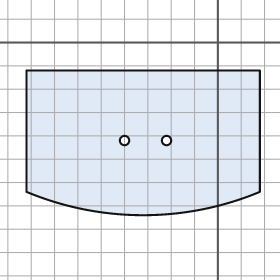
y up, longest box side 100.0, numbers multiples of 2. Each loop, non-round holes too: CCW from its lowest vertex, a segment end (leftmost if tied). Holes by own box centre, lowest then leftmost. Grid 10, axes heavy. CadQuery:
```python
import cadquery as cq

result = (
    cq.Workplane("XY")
    .moveTo(-82.0, -64.0)
    .threePointArc((-32.0, -74.0), (18.0, -64.0))
    .lineTo(18.0, -12.0)
    .lineTo(-82.0, -12.0)
    .close()
    .moveTo(-40.0, -42.0)
    .circle(2.0)
    .moveTo(-22.0, -42.0)
    .circle(2.0)
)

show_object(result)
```